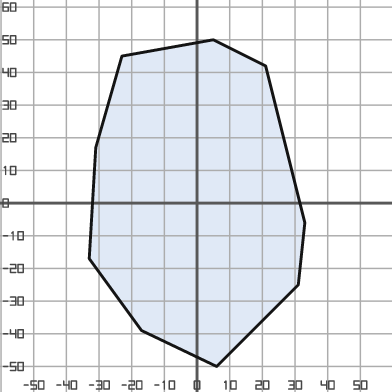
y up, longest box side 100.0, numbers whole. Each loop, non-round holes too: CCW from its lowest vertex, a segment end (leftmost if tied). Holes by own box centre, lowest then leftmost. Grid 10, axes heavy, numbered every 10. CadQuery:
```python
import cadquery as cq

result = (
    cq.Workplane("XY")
    .moveTo(6.0, -50.0)
    .lineTo(31.0, -25.0)
    .lineTo(33.0, -6.0)
    .lineTo(21.0, 42.0)
    .lineTo(5.0, 50.0)
    .lineTo(-23.0, 45.0)
    .lineTo(-31.0, 17.0)
    .lineTo(-33.0, -17.0)
    .lineTo(-17.0, -39.0)
    .close()
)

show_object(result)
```